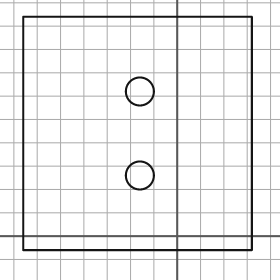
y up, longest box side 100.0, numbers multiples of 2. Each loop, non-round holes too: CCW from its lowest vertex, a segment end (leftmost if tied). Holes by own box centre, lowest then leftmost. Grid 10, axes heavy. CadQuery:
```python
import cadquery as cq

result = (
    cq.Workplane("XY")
    .moveTo(-66.0, -6.0)
    .lineTo(32.0, -6.0)
    .lineTo(32.0, 94.0)
    .lineTo(-66.0, 94.0)
    .close()
    .moveTo(-16.0, 26.0)
    .circle(6.0)
    .moveTo(-16.0, 62.0)
    .circle(6.0)
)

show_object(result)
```